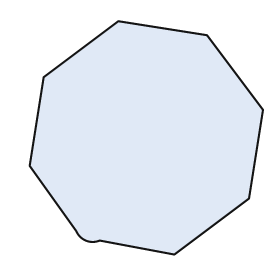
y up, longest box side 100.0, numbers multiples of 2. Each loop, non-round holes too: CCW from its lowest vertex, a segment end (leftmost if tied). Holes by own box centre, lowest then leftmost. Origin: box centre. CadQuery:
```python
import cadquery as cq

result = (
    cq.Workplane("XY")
    .moveTo(12.0, -50.0)
    .lineTo(44.0, -26.0)
    .lineTo(50.0, 12.0)
    .lineTo(26.0, 44.0)
    .lineTo(-12.0, 50.0)
    .lineTo(-44.0, 26.0)
    .lineTo(-50.0, -12.0)
    .lineTo(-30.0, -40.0)
    .threePointArc((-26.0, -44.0), (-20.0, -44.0))
    .close()
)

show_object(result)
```